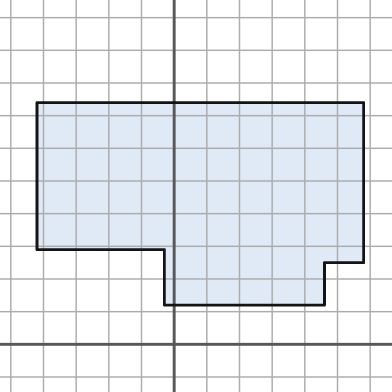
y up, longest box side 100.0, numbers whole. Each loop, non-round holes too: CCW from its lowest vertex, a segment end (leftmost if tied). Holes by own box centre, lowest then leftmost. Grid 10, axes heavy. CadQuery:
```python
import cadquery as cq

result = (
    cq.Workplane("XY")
    .moveTo(-3.0, 12.0)
    .lineTo(46.0, 12.0)
    .lineTo(46.0, 25.0)
    .lineTo(58.0, 25.0)
    .lineTo(58.0, 74.0)
    .lineTo(-42.0, 74.0)
    .lineTo(-42.0, 29.0)
    .lineTo(-3.0, 29.0)
    .close()
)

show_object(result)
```